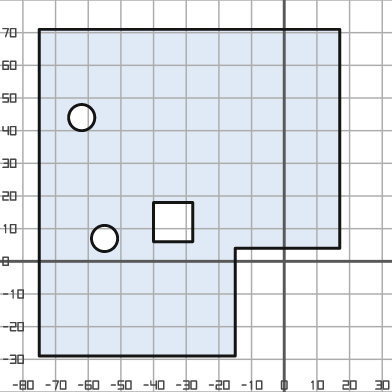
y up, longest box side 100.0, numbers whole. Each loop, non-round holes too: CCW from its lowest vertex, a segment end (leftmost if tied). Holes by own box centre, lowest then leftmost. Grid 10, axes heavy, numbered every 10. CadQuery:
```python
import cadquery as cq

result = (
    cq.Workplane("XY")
    .moveTo(-75.0, -29.0)
    .lineTo(-15.0, -29.0)
    .lineTo(-15.0, 4.0)
    .lineTo(17.0, 4.0)
    .lineTo(17.0, 71.0)
    .lineTo(-75.0, 71.0)
    .close()
    .moveTo(-55.0, 7.0)
    .circle(4.0)
    .moveTo(-40.0, 6.0)
    .lineTo(-28.0, 6.0)
    .lineTo(-28.0, 18.0)
    .lineTo(-40.0, 18.0)
    .close()
    .moveTo(-62.0, 44.0)
    .circle(4.0)
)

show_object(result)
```